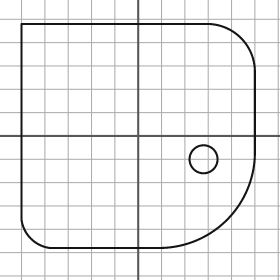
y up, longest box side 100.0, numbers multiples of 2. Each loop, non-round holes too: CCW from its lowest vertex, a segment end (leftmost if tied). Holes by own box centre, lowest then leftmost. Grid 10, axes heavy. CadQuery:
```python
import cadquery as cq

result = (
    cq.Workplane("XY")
    .moveTo(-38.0, -48.0)
    .lineTo(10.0, -48.0)
    .threePointArc((38.0, -36.0), (50.0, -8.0))
    .lineTo(50.0, 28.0)
    .threePointArc((44.0, 42.0), (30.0, 48.0))
    .lineTo(-50.0, 48.0)
    .lineTo(-50.0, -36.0)
    .threePointArc((-46.0, -44.0), (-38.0, -48.0))
    .close()
    .moveTo(28.0, -10.0)
    .circle(6.0)
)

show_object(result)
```